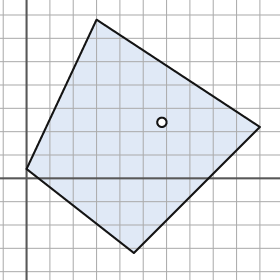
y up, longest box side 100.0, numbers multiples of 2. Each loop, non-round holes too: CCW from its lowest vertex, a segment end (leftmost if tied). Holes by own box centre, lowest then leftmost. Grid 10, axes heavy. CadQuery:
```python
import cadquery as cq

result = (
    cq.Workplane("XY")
    .moveTo(46.0, -32.0)
    .lineTo(100.0, 22.0)
    .lineTo(30.0, 68.0)
    .lineTo(0.0, 4.0)
    .close()
    .moveTo(58.0, 24.0)
    .circle(2.0)
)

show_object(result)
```